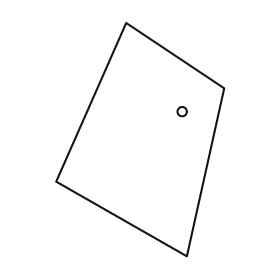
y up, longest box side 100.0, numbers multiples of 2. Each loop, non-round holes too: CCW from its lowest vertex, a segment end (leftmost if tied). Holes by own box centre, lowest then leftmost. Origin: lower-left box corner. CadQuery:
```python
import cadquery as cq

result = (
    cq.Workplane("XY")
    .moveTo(56.0, 0.0)
    .lineTo(72.0, 72.0)
    .lineTo(30.0, 100.0)
    .lineTo(0.0, 32.0)
    .close()
    .moveTo(54.0, 62.0)
    .circle(2.0)
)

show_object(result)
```